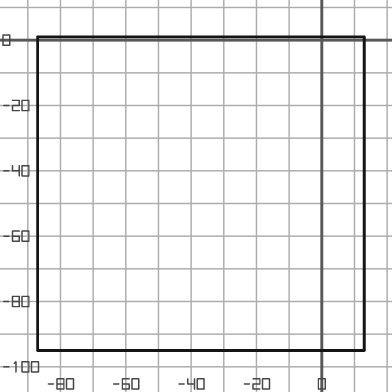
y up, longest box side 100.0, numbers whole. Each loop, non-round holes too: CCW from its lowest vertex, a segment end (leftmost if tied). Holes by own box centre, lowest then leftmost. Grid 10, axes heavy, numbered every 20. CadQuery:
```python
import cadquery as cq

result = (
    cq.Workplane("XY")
    .moveTo(-87.0, -95.0)
    .lineTo(13.0, -95.0)
    .lineTo(13.0, 1.0)
    .lineTo(-87.0, 1.0)
    .close()
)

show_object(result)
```